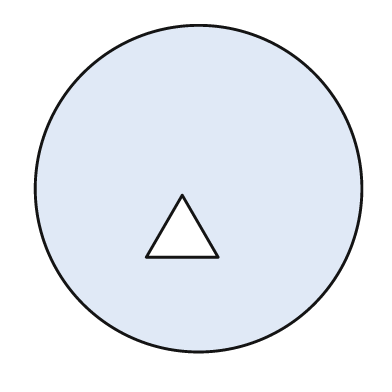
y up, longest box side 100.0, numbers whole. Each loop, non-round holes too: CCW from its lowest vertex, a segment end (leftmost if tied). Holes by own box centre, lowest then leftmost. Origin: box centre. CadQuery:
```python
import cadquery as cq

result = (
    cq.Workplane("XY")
    .moveTo(0.0, 0.0)
    .circle(50.0)
    .moveTo(-16.0, -21.0)
    .lineTo(6.0, -21.0)
    .lineTo(-5.0, -2.0)
    .close()
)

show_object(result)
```